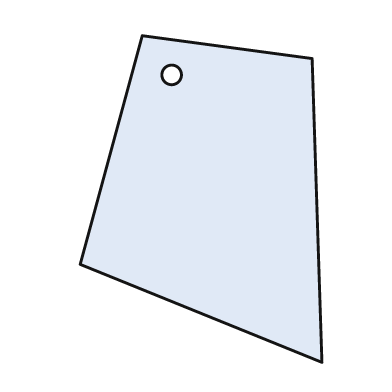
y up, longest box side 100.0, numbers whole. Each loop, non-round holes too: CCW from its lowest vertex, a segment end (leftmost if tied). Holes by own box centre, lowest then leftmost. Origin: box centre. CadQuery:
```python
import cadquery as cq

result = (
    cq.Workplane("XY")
    .moveTo(37.0, -50.0)
    .lineTo(34.0, 43.0)
    .lineTo(-18.0, 50.0)
    .lineTo(-37.0, -20.0)
    .close()
    .moveTo(-9.0, 38.0)
    .circle(3.0)
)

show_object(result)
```